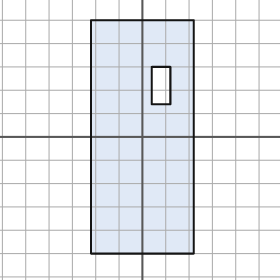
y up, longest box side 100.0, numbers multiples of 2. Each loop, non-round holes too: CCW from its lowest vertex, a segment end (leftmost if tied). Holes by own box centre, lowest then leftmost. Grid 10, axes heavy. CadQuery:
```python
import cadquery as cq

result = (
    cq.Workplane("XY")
    .moveTo(-22.0, -50.0)
    .lineTo(22.0, -50.0)
    .lineTo(22.0, 50.0)
    .lineTo(-22.0, 50.0)
    .close()
    .moveTo(4.0, 14.0)
    .lineTo(12.0, 14.0)
    .lineTo(12.0, 30.0)
    .lineTo(4.0, 30.0)
    .close()
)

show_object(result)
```